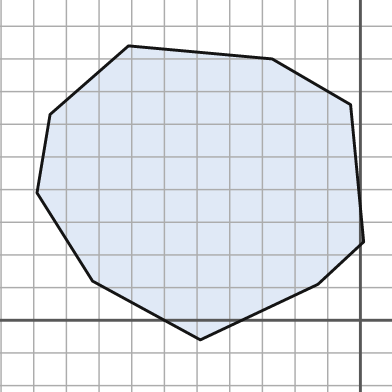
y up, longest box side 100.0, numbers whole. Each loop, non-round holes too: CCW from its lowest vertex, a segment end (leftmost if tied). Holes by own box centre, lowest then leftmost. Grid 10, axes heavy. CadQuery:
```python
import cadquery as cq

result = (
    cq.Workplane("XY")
    .moveTo(-49.0, -6.0)
    .lineTo(-13.0, 11.0)
    .lineTo(1.0, 24.0)
    .lineTo(-3.0, 66.0)
    .lineTo(-27.0, 80.0)
    .lineTo(-71.0, 84.0)
    .lineTo(-95.0, 63.0)
    .lineTo(-99.0, 39.0)
    .lineTo(-82.0, 12.0)
    .close()
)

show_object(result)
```